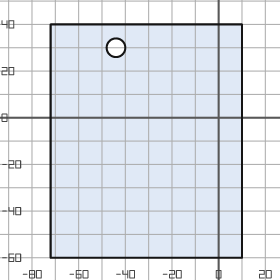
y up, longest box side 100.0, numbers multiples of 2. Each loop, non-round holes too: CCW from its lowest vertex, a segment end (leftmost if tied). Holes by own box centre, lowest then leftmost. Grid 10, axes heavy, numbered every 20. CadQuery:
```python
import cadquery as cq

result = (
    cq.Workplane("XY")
    .moveTo(-72.0, -60.0)
    .lineTo(10.0, -60.0)
    .lineTo(10.0, 40.0)
    .lineTo(-72.0, 40.0)
    .close()
    .moveTo(-44.0, 30.0)
    .circle(4.0)
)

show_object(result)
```